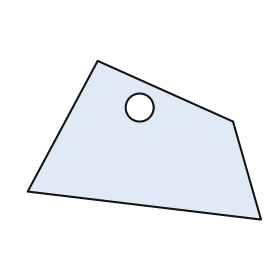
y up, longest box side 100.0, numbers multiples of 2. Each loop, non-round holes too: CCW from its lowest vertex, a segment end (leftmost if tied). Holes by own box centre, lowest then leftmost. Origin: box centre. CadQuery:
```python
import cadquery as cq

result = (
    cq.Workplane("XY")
    .moveTo(50.0, -34.0)
    .lineTo(38.0, 8.0)
    .lineTo(-20.0, 34.0)
    .lineTo(-50.0, -22.0)
    .close()
    .moveTo(-2.0, 14.0)
    .circle(6.0)
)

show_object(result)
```